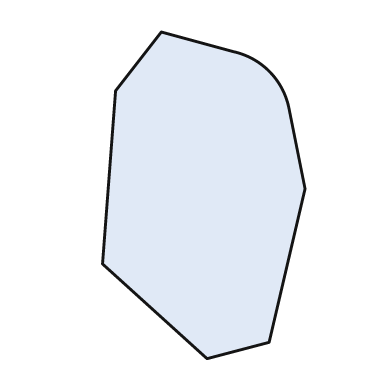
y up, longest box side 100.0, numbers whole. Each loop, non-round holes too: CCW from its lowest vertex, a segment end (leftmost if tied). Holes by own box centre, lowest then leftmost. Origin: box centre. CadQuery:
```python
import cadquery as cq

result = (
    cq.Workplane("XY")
    .moveTo(1.0, -50.0)
    .lineTo(20.0, -45.0)
    .lineTo(31.0, 2.0)
    .lineTo(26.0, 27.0)
    .threePointArc((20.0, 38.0), (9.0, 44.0))
    .lineTo(-13.0, 50.0)
    .lineTo(-27.0, 32.0)
    .lineTo(-31.0, -21.0)
    .close()
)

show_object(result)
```